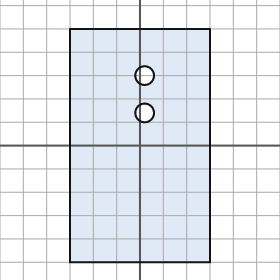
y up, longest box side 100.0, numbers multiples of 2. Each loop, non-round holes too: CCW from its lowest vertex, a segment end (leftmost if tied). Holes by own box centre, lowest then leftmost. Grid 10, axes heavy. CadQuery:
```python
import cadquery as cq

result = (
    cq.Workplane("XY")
    .moveTo(-30.0, -50.0)
    .lineTo(30.0, -50.0)
    .lineTo(30.0, 50.0)
    .lineTo(-30.0, 50.0)
    .close()
    .moveTo(2.0, 14.0)
    .circle(4.0)
    .moveTo(2.0, 30.0)
    .circle(4.0)
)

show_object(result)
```